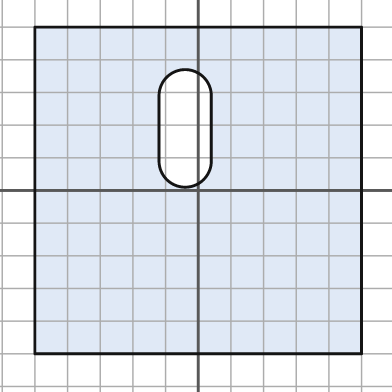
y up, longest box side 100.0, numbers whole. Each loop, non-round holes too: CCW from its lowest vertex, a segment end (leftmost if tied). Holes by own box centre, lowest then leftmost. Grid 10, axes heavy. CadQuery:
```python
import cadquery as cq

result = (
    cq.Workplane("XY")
    .moveTo(-50.0, -50.0)
    .lineTo(50.0, -50.0)
    .lineTo(50.0, 50.0)
    .lineTo(-50.0, 50.0)
    .close()
    .moveTo(-12.0, 9.0)
    .threePointArc((-4.0, 1.0), (4.0, 9.0))
    .lineTo(4.0, 29.0)
    .threePointArc((-4.0, 37.0), (-12.0, 29.0))
    .close()
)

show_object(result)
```